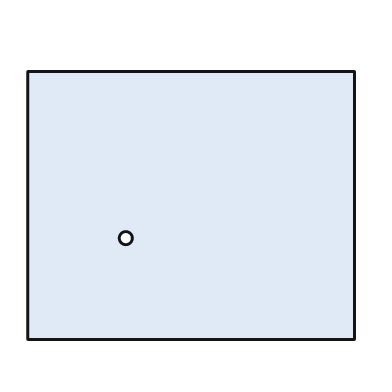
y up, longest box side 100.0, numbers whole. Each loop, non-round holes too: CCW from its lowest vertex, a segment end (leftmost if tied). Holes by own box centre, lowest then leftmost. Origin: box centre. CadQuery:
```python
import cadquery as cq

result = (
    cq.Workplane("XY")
    .moveTo(-50.0, -41.0)
    .lineTo(50.0, -41.0)
    .lineTo(50.0, 41.0)
    .lineTo(-50.0, 41.0)
    .close()
    .moveTo(-20.0, -10.0)
    .circle(2.0)
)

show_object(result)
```